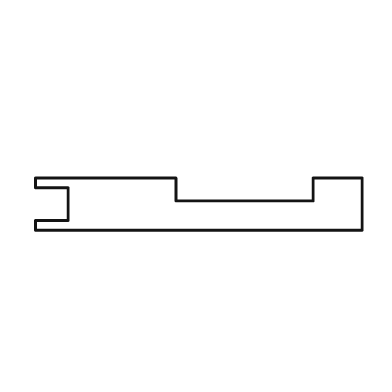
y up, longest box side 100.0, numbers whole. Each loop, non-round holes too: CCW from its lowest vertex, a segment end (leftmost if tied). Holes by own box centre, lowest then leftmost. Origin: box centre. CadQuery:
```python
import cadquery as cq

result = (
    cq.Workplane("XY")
    .moveTo(-50.0, -8.0)
    .lineTo(50.0, -8.0)
    .lineTo(50.0, 8.0)
    .lineTo(35.0, 8.0)
    .lineTo(35.0, 1.0)
    .lineTo(-7.0, 1.0)
    .lineTo(-7.0, 8.0)
    .lineTo(-50.0, 8.0)
    .lineTo(-50.0, 5.0)
    .lineTo(-40.0, 5.0)
    .lineTo(-40.0, -5.0)
    .lineTo(-50.0, -5.0)
    .close()
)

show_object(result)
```